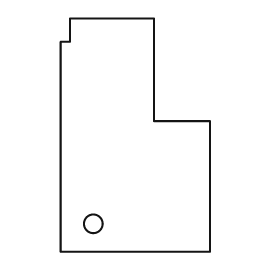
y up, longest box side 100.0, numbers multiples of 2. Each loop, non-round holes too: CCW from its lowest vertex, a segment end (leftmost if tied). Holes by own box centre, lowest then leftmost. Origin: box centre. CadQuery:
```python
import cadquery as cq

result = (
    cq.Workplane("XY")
    .moveTo(-32.0, -50.0)
    .lineTo(32.0, -50.0)
    .lineTo(32.0, 6.0)
    .lineTo(8.0, 6.0)
    .lineTo(8.0, 50.0)
    .lineTo(-28.0, 50.0)
    .lineTo(-28.0, 40.0)
    .lineTo(-32.0, 40.0)
    .close()
    .moveTo(-18.0, -38.0)
    .circle(4.0)
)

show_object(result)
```